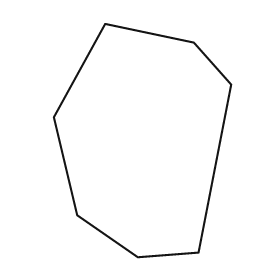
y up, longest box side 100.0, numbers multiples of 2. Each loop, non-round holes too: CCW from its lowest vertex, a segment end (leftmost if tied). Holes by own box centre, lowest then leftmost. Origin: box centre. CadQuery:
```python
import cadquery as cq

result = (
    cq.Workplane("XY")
    .moveTo(-2.0, -50.0)
    .lineTo(24.0, -48.0)
    .lineTo(38.0, 24.0)
    .lineTo(22.0, 42.0)
    .lineTo(-16.0, 50.0)
    .lineTo(-38.0, 10.0)
    .lineTo(-28.0, -32.0)
    .close()
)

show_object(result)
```